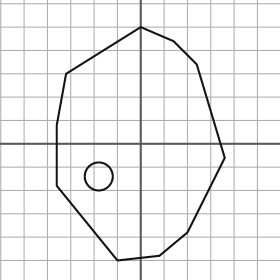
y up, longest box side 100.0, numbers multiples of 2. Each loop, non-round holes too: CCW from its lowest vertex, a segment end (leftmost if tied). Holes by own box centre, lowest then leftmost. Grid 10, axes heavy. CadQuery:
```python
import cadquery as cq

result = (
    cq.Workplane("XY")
    .moveTo(-10.0, -50.0)
    .lineTo(8.0, -48.0)
    .lineTo(20.0, -38.0)
    .lineTo(36.0, -6.0)
    .lineTo(24.0, 34.0)
    .lineTo(14.0, 44.0)
    .lineTo(0.0, 50.0)
    .lineTo(-32.0, 30.0)
    .lineTo(-36.0, 8.0)
    .lineTo(-36.0, -18.0)
    .close()
    .moveTo(-18.0, -14.0)
    .circle(6.0)
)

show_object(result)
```